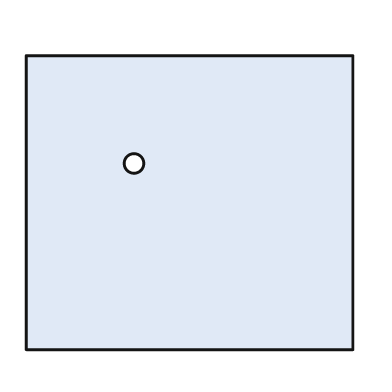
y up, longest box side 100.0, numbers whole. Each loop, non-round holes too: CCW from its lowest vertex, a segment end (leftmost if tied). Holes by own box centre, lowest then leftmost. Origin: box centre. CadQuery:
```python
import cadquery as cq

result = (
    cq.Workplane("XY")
    .moveTo(-50.0, -45.0)
    .lineTo(50.0, -45.0)
    .lineTo(50.0, 45.0)
    .lineTo(-50.0, 45.0)
    .close()
    .moveTo(-17.0, 12.0)
    .circle(3.0)
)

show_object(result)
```